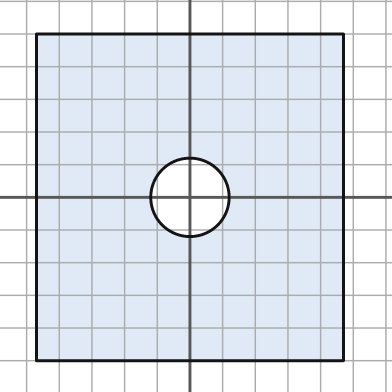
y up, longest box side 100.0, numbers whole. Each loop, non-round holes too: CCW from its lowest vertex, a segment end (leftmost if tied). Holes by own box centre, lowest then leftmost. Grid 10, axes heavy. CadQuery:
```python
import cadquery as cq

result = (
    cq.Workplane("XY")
    .moveTo(-47.0, -50.0)
    .lineTo(47.0, -50.0)
    .lineTo(47.0, 50.0)
    .lineTo(-47.0, 50.0)
    .close()
    .moveTo(0.0, 0.0)
    .circle(12.0)
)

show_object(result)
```